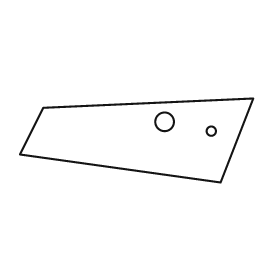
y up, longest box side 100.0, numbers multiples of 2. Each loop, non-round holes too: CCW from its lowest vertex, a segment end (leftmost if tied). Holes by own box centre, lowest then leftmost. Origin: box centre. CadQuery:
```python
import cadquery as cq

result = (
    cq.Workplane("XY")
    .moveTo(36.0, -18.0)
    .lineTo(50.0, 18.0)
    .lineTo(-40.0, 14.0)
    .lineTo(-50.0, -6.0)
    .close()
    .moveTo(32.0, 4.0)
    .circle(2.0)
    .moveTo(12.0, 8.0)
    .circle(4.0)
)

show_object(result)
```